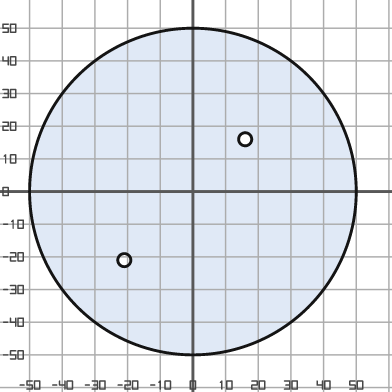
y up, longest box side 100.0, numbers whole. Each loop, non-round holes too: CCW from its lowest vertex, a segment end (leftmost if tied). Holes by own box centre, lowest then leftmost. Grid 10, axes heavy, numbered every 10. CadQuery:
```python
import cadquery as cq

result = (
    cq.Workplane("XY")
    .moveTo(0.0, 0.0)
    .circle(50.0)
    .moveTo(-21.0, -21.0)
    .circle(2.0)
    .moveTo(16.0, 16.0)
    .circle(2.0)
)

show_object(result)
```